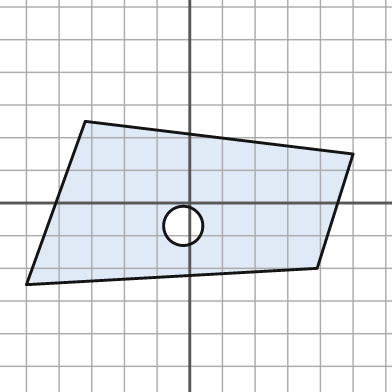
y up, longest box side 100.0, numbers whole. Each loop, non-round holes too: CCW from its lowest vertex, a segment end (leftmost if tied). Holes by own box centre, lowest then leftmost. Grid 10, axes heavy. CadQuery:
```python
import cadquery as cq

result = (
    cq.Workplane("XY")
    .moveTo(-50.0, -25.0)
    .lineTo(39.0, -20.0)
    .lineTo(50.0, 15.0)
    .lineTo(-32.0, 25.0)
    .close()
    .moveTo(-2.0, -7.0)
    .circle(6.0)
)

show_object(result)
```